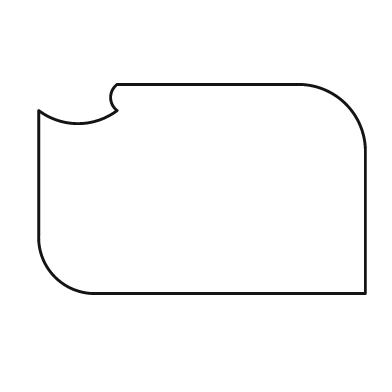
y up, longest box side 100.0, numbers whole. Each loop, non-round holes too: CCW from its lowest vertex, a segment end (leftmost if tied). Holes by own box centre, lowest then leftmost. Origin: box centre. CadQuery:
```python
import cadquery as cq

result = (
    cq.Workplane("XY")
    .moveTo(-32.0, -32.0)
    .lineTo(50.0, -32.0)
    .lineTo(50.0, 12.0)
    .threePointArc((44.0, 26.0), (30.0, 32.0))
    .lineTo(-26.0, 32.0)
    .threePointArc((-28.0, 28.0), (-26.0, 24.0))
    .threePointArc((-38.0, 20.0), (-50.0, 24.0))
    .lineTo(-50.0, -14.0)
    .threePointArc((-45.0, -27.0), (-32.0, -32.0))
    .close()
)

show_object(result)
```